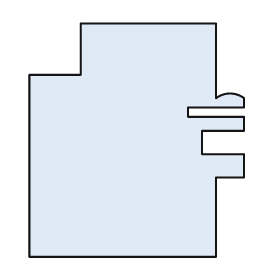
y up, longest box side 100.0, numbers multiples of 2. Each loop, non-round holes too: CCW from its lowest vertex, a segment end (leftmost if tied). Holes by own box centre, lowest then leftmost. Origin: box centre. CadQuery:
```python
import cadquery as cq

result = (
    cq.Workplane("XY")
    .moveTo(-46.0, -50.0)
    .lineTo(34.0, -50.0)
    .lineTo(34.0, -16.0)
    .lineTo(46.0, -16.0)
    .lineTo(46.0, -6.0)
    .lineTo(28.0, -6.0)
    .lineTo(28.0, 4.0)
    .lineTo(46.0, 4.0)
    .lineTo(46.0, 10.0)
    .lineTo(22.0, 10.0)
    .lineTo(22.0, 14.0)
    .lineTo(46.0, 14.0)
    .lineTo(46.0, 18.0)
    .threePointArc((40.0, 20.0), (34.0, 18.0))
    .lineTo(34.0, 50.0)
    .lineTo(-24.0, 50.0)
    .lineTo(-24.0, 28.0)
    .lineTo(-46.0, 28.0)
    .close()
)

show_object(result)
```